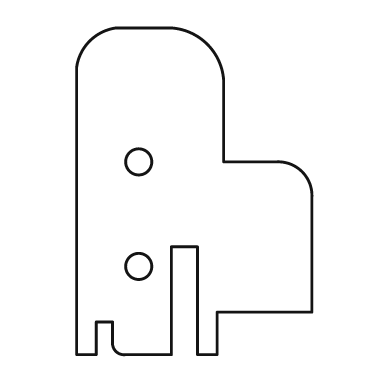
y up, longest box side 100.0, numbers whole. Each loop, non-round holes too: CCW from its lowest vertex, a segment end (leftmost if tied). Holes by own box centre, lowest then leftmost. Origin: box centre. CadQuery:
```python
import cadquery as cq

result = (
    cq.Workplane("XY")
    .moveTo(-36.0, -50.0)
    .lineTo(-30.0, -50.0)
    .lineTo(-30.0, -40.0)
    .lineTo(-25.0, -40.0)
    .lineTo(-25.0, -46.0)
    .threePointArc((-24.0, -49.0), (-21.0, -50.0))
    .lineTo(-7.0, -50.0)
    .lineTo(-7.0, -17.0)
    .lineTo(1.0, -17.0)
    .lineTo(1.0, -50.0)
    .lineTo(7.0, -50.0)
    .lineTo(7.0, -37.0)
    .lineTo(36.0, -37.0)
    .lineTo(36.0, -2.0)
    .threePointArc((33.0, 6.0), (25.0, 9.0))
    .lineTo(9.0, 9.0)
    .lineTo(9.0, 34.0)
    .threePointArc((4.0, 45.0), (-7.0, 50.0))
    .lineTo(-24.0, 50.0)
    .threePointArc((-32.0, 46.0), (-36.0, 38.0))
    .close()
    .moveTo(-17.0, -23.0)
    .circle(4.0)
    .moveTo(-17.0, 9.0)
    .circle(4.0)
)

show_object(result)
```